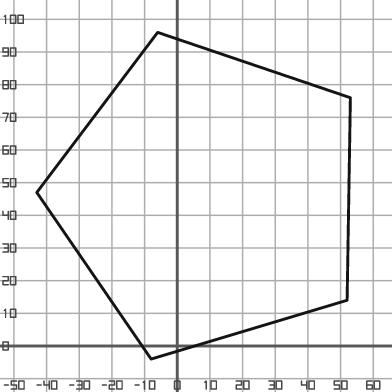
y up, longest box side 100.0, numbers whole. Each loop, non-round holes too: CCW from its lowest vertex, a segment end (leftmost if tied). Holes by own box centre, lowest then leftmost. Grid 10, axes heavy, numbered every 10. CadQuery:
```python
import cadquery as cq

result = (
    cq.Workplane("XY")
    .moveTo(-8.0, -4.0)
    .lineTo(52.0, 14.0)
    .lineTo(53.0, 76.0)
    .lineTo(-6.0, 96.0)
    .lineTo(-43.0, 47.0)
    .close()
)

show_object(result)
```